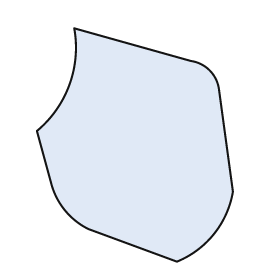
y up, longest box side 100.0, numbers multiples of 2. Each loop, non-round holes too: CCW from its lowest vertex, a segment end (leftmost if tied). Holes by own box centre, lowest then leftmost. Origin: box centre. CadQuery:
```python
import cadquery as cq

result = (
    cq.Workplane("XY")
    .moveTo(18.0, -50.0)
    .threePointArc((34.0, -38.0), (42.0, -20.0))
    .lineTo(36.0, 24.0)
    .threePointArc((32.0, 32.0), (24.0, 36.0))
    .lineTo(-26.0, 50.0)
    .threePointArc((-28.0, 26.0), (-42.0, 6.0))
    .lineTo(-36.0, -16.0)
    .threePointArc((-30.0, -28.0), (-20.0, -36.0))
    .close()
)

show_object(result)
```